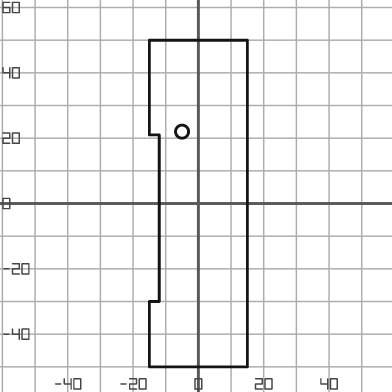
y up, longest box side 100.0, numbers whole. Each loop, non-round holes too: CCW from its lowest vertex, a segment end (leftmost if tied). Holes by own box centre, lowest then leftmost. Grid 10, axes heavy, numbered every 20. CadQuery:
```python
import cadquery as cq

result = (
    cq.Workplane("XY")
    .moveTo(-15.0, -50.0)
    .lineTo(15.0, -50.0)
    .lineTo(15.0, 50.0)
    .lineTo(-15.0, 50.0)
    .lineTo(-15.0, 21.0)
    .lineTo(-12.0, 21.0)
    .lineTo(-12.0, -30.0)
    .lineTo(-15.0, -30.0)
    .close()
    .moveTo(-5.0, 22.0)
    .circle(2.0)
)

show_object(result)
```